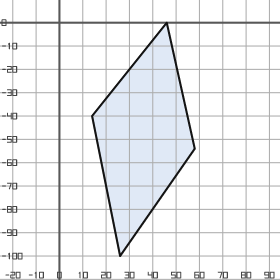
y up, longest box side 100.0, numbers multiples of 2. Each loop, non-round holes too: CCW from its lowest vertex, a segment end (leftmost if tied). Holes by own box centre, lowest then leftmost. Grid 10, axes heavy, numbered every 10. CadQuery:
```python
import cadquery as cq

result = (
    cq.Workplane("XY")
    .moveTo(26.0, -100.0)
    .lineTo(58.0, -54.0)
    .lineTo(46.0, 0.0)
    .lineTo(14.0, -40.0)
    .close()
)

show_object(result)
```